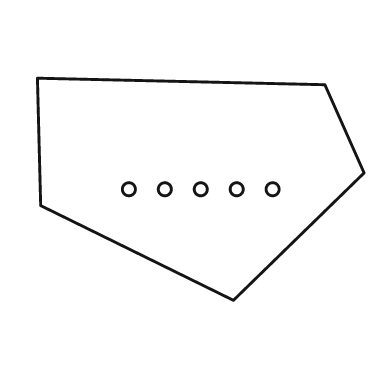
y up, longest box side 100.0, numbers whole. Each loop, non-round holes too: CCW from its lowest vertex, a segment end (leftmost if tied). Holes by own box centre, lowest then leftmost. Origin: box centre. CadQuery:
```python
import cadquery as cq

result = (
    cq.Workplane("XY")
    .moveTo(10.0, -34.0)
    .lineTo(50.0, 5.0)
    .lineTo(38.0, 32.0)
    .lineTo(-50.0, 34.0)
    .lineTo(-49.0, -5.0)
    .close()
    .moveTo(-22.0, 0.0)
    .circle(2.0)
    .moveTo(-11.0, 0.0)
    .circle(2.0)
    .moveTo(0.0, 0.0)
    .circle(2.0)
    .moveTo(11.0, 0.0)
    .circle(2.0)
    .moveTo(22.0, 0.0)
    .circle(2.0)
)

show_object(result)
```